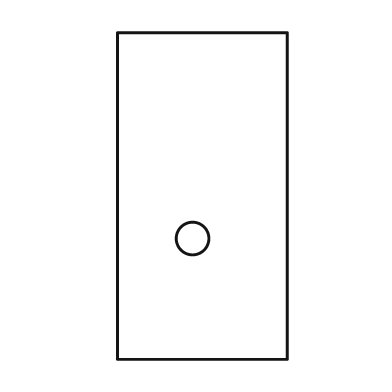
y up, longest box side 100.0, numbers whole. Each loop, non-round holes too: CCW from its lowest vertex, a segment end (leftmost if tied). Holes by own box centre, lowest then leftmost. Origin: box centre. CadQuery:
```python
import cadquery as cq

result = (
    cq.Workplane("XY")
    .moveTo(-26.0, -50.0)
    .lineTo(26.0, -50.0)
    .lineTo(26.0, 50.0)
    .lineTo(-26.0, 50.0)
    .close()
    .moveTo(-3.0, -13.0)
    .circle(5.0)
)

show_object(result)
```